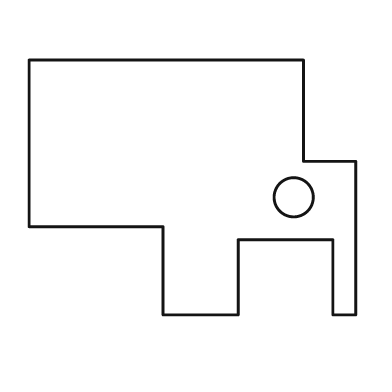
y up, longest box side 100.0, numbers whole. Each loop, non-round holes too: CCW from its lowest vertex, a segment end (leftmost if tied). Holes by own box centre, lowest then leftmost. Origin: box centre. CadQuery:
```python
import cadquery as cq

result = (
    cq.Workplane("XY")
    .moveTo(-9.0, -39.0)
    .lineTo(14.0, -39.0)
    .lineTo(14.0, -16.0)
    .lineTo(43.0, -16.0)
    .lineTo(43.0, -39.0)
    .lineTo(50.0, -39.0)
    .lineTo(50.0, 8.0)
    .lineTo(34.0, 8.0)
    .lineTo(34.0, 39.0)
    .lineTo(-50.0, 39.0)
    .lineTo(-50.0, -12.0)
    .lineTo(-9.0, -12.0)
    .close()
    .moveTo(31.0, -3.0)
    .circle(6.0)
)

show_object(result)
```